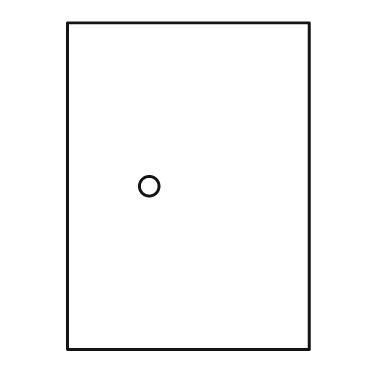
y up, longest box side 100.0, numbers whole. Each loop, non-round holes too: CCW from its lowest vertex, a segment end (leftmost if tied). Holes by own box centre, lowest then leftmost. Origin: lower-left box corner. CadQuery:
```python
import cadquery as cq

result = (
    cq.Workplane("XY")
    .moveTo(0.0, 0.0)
    .lineTo(74.0, 0.0)
    .lineTo(74.0, 100.0)
    .lineTo(0.0, 100.0)
    .close()
    .moveTo(25.0, 50.0)
    .circle(3.0)
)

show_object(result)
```